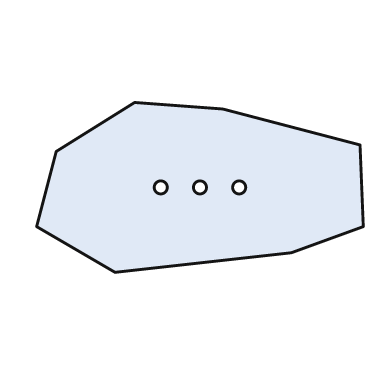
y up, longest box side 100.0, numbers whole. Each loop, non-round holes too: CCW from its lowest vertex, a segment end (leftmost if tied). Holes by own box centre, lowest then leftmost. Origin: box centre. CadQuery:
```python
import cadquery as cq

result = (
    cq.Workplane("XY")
    .moveTo(-26.0, -26.0)
    .lineTo(28.0, -20.0)
    .lineTo(50.0, -12.0)
    .lineTo(49.0, 13.0)
    .lineTo(7.0, 24.0)
    .lineTo(-20.0, 26.0)
    .lineTo(-44.0, 11.0)
    .lineTo(-50.0, -12.0)
    .close()
    .moveTo(-12.0, 0.0)
    .circle(2.0)
    .moveTo(0.0, 0.0)
    .circle(2.0)
    .moveTo(12.0, 0.0)
    .circle(2.0)
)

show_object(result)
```